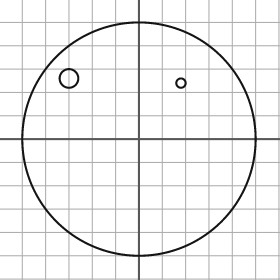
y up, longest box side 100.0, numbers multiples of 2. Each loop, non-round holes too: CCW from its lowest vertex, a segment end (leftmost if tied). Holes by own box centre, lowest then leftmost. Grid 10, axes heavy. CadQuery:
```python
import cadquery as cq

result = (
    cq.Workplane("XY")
    .moveTo(0.0, 0.0)
    .circle(50.0)
    .moveTo(18.0, 24.0)
    .circle(2.0)
    .moveTo(-30.0, 26.0)
    .circle(4.0)
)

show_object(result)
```